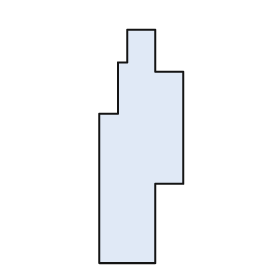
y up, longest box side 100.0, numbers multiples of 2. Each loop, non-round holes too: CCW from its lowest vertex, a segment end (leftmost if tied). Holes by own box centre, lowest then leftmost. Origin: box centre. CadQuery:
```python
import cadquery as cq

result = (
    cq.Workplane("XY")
    .moveTo(-18.0, -50.0)
    .lineTo(6.0, -50.0)
    .lineTo(6.0, -16.0)
    .lineTo(18.0, -16.0)
    .lineTo(18.0, 32.0)
    .lineTo(6.0, 32.0)
    .lineTo(6.0, 50.0)
    .lineTo(-6.0, 50.0)
    .lineTo(-6.0, 36.0)
    .lineTo(-10.0, 36.0)
    .lineTo(-10.0, 14.0)
    .lineTo(-18.0, 14.0)
    .close()
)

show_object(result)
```